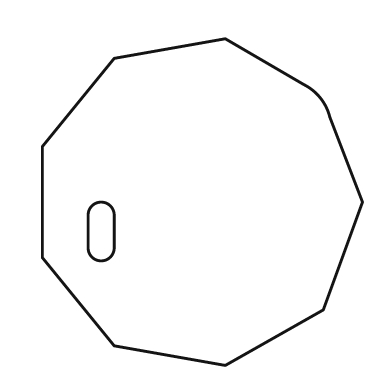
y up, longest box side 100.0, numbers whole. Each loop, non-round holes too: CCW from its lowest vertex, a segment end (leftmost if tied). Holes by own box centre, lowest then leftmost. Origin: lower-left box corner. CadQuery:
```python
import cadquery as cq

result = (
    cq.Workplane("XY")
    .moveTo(56.0, 0.0)
    .lineTo(86.0, 17.0)
    .lineTo(98.0, 50.0)
    .lineTo(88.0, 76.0)
    .threePointArc((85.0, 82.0), (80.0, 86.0))
    .lineTo(56.0, 100.0)
    .lineTo(22.0, 94.0)
    .lineTo(0.0, 67.0)
    .lineTo(0.0, 33.0)
    .lineTo(22.0, 6.0)
    .close()
    .moveTo(14.0, 36.0)
    .threePointArc((18.0, 32.0), (22.0, 36.0))
    .lineTo(22.0, 46.0)
    .threePointArc((18.0, 50.0), (14.0, 46.0))
    .close()
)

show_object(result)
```